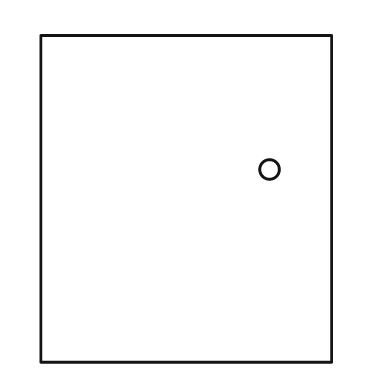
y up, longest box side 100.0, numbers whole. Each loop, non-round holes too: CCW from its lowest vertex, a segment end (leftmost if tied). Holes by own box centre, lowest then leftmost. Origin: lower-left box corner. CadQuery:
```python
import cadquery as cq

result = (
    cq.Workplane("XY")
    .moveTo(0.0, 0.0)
    .lineTo(89.0, 0.0)
    .lineTo(89.0, 100.0)
    .lineTo(0.0, 100.0)
    .close()
    .moveTo(70.0, 59.0)
    .circle(3.0)
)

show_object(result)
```